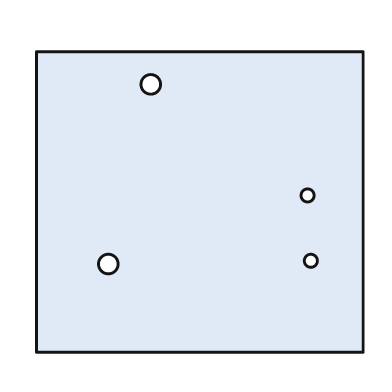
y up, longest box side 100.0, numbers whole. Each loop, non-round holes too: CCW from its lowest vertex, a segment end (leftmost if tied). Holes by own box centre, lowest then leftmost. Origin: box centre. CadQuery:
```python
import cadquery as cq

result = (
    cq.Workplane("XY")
    .moveTo(-50.0, -46.0)
    .lineTo(50.0, -46.0)
    .lineTo(50.0, 46.0)
    .lineTo(-50.0, 46.0)
    .close()
    .moveTo(-28.0, -19.0)
    .circle(3.0)
    .moveTo(34.0, -18.0)
    .circle(2.0)
    .moveTo(33.0, 2.0)
    .circle(2.0)
    .moveTo(-15.0, 36.0)
    .circle(3.0)
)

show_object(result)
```